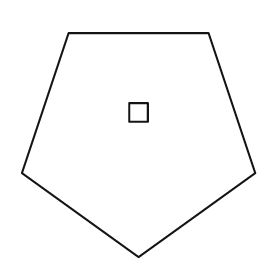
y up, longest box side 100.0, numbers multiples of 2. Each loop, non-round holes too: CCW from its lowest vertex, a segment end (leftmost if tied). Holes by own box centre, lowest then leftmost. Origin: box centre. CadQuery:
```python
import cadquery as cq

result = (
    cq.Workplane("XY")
    .moveTo(0.0, -48.0)
    .lineTo(50.0, -12.0)
    .lineTo(30.0, 48.0)
    .lineTo(-30.0, 48.0)
    .lineTo(-50.0, -12.0)
    .close()
    .moveTo(-4.0, 10.0)
    .lineTo(4.0, 10.0)
    .lineTo(4.0, 18.0)
    .lineTo(-4.0, 18.0)
    .close()
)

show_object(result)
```